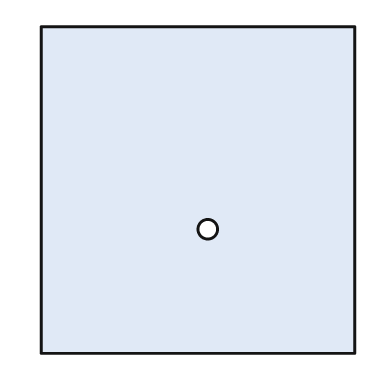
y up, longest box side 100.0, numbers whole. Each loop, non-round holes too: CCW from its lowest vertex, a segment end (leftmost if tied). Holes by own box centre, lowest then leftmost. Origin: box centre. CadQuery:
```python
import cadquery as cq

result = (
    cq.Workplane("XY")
    .moveTo(-48.0, -50.0)
    .lineTo(48.0, -50.0)
    .lineTo(48.0, 50.0)
    .lineTo(-48.0, 50.0)
    .close()
    .moveTo(3.0, -12.0)
    .circle(3.0)
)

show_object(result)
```